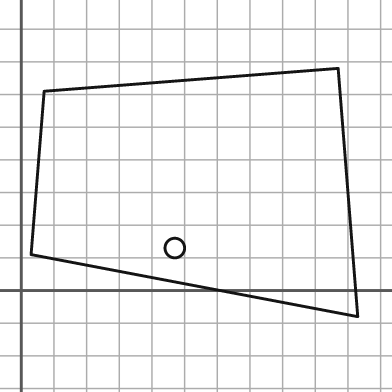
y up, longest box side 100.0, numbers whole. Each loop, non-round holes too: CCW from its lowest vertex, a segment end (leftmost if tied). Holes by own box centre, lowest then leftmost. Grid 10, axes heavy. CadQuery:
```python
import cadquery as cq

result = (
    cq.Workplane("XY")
    .moveTo(103.0, -8.0)
    .lineTo(97.0, 68.0)
    .lineTo(7.0, 61.0)
    .lineTo(3.0, 11.0)
    .close()
    .moveTo(47.0, 13.0)
    .circle(3.0)
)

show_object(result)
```